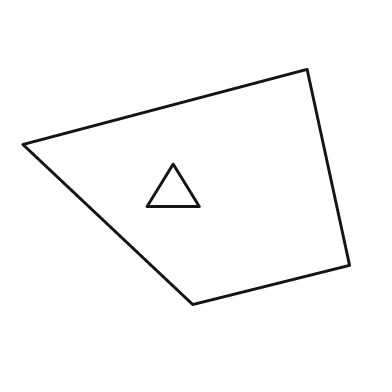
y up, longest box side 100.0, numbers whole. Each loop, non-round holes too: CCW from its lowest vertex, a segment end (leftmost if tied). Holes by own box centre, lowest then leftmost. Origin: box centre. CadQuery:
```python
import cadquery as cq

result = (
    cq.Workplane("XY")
    .moveTo(2.0, -36.0)
    .lineTo(50.0, -24.0)
    .lineTo(37.0, 36.0)
    .lineTo(-50.0, 13.0)
    .close()
    .moveTo(-12.0, -6.0)
    .lineTo(4.0, -6.0)
    .lineTo(-4.0, 7.0)
    .close()
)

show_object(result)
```